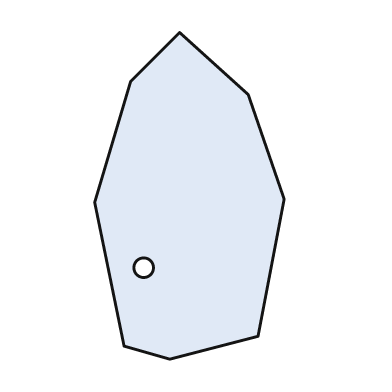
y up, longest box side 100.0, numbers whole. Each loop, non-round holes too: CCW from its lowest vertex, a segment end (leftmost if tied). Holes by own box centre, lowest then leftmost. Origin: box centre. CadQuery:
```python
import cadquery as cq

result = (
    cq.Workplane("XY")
    .moveTo(-6.0, -50.0)
    .lineTo(21.0, -43.0)
    .lineTo(29.0, -1.0)
    .lineTo(18.0, 31.0)
    .lineTo(-3.0, 50.0)
    .lineTo(-18.0, 35.0)
    .lineTo(-29.0, -2.0)
    .lineTo(-20.0, -46.0)
    .close()
    .moveTo(-14.0, -22.0)
    .circle(3.0)
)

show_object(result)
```